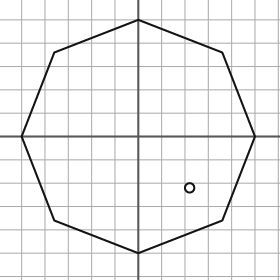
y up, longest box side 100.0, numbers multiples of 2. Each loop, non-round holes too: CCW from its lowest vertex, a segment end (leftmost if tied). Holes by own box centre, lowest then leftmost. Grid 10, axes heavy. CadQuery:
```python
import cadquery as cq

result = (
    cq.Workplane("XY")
    .moveTo(0.0, -50.0)
    .lineTo(36.0, -36.0)
    .lineTo(50.0, 0.0)
    .lineTo(36.0, 36.0)
    .lineTo(0.0, 50.0)
    .lineTo(-36.0, 36.0)
    .lineTo(-50.0, 0.0)
    .lineTo(-36.0, -36.0)
    .close()
    .moveTo(22.0, -22.0)
    .circle(2.0)
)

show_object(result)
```